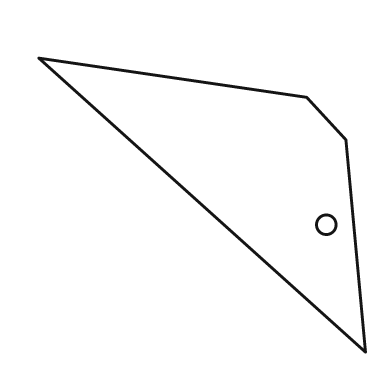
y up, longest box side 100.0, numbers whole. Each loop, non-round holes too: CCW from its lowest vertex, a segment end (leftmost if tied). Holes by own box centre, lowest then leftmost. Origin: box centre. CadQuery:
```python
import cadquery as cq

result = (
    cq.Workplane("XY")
    .moveTo(50.0, -45.0)
    .lineTo(44.0, 20.0)
    .lineTo(32.0, 33.0)
    .lineTo(-50.0, 45.0)
    .close()
    .moveTo(38.0, -6.0)
    .circle(3.0)
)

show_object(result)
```